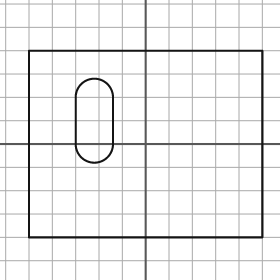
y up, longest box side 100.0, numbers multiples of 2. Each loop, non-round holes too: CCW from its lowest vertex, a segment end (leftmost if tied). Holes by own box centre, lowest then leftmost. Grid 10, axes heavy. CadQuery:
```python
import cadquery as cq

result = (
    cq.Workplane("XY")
    .moveTo(-50.0, -40.0)
    .lineTo(50.0, -40.0)
    .lineTo(50.0, 40.0)
    .lineTo(-50.0, 40.0)
    .close()
    .moveTo(-30.0, 0.0)
    .threePointArc((-22.0, -8.0), (-14.0, 0.0))
    .lineTo(-14.0, 20.0)
    .threePointArc((-22.0, 28.0), (-30.0, 20.0))
    .close()
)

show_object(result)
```